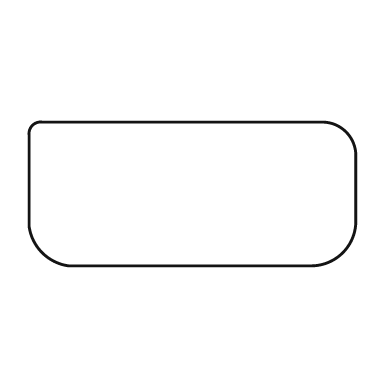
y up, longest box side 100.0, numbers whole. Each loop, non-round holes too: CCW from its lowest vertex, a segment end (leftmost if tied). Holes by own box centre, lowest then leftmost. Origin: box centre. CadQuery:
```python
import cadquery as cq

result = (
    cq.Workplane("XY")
    .moveTo(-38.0, -22.0)
    .lineTo(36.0, -22.0)
    .threePointArc((46.0, -18.0), (50.0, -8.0))
    .lineTo(50.0, 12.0)
    .threePointArc((47.0, 19.0), (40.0, 22.0))
    .lineTo(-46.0, 22.0)
    .threePointArc((-49.0, 21.0), (-50.0, 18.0))
    .lineTo(-50.0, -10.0)
    .threePointArc((-46.0, -18.0), (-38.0, -22.0))
    .close()
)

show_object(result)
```